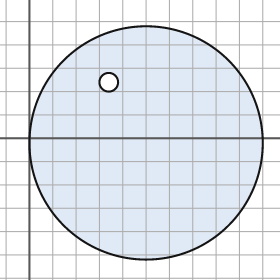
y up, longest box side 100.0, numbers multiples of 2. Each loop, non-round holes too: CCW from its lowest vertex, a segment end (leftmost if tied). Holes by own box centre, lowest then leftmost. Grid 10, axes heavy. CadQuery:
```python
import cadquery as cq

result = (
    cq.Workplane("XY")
    .moveTo(50.0, -2.0)
    .circle(50.0)
    .moveTo(34.0, 24.0)
    .circle(4.0)
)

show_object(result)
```